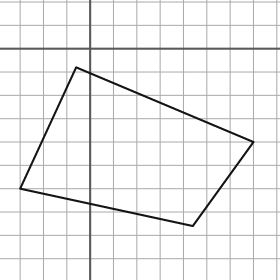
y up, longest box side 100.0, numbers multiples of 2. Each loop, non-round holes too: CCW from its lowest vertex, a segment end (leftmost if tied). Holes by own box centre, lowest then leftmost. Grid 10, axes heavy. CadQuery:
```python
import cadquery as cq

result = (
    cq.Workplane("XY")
    .moveTo(44.0, -76.0)
    .lineTo(70.0, -40.0)
    .lineTo(-6.0, -8.0)
    .lineTo(-30.0, -60.0)
    .close()
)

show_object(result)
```